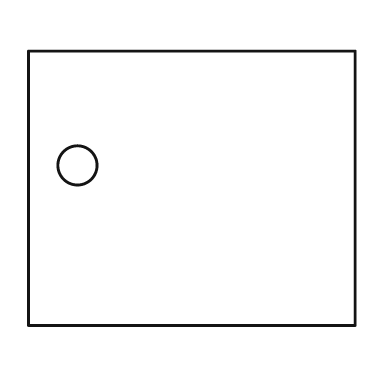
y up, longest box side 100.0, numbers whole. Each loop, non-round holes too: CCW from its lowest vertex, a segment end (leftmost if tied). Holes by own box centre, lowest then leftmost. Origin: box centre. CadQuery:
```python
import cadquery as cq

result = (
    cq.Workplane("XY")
    .moveTo(-50.0, -42.0)
    .lineTo(50.0, -42.0)
    .lineTo(50.0, 42.0)
    .lineTo(-50.0, 42.0)
    .close()
    .moveTo(-35.0, 7.0)
    .circle(6.0)
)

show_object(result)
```